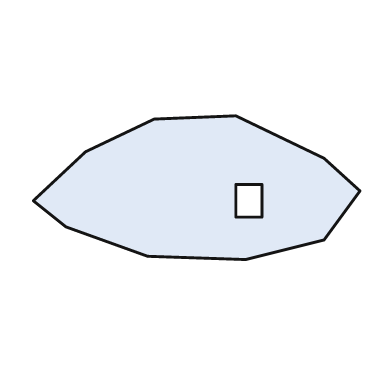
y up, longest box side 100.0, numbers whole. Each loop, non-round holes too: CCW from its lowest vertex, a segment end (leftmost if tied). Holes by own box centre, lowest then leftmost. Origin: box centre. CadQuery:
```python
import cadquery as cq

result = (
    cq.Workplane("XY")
    .moveTo(15.0, -22.0)
    .lineTo(39.0, -16.0)
    .lineTo(50.0, -1.0)
    .lineTo(39.0, 9.0)
    .lineTo(12.0, 22.0)
    .lineTo(-13.0, 21.0)
    .lineTo(-34.0, 11.0)
    .lineTo(-50.0, -4.0)
    .lineTo(-40.0, -12.0)
    .lineTo(-15.0, -21.0)
    .close()
    .moveTo(12.0, -9.0)
    .lineTo(20.0, -9.0)
    .lineTo(20.0, 1.0)
    .lineTo(12.0, 1.0)
    .close()
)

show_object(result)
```